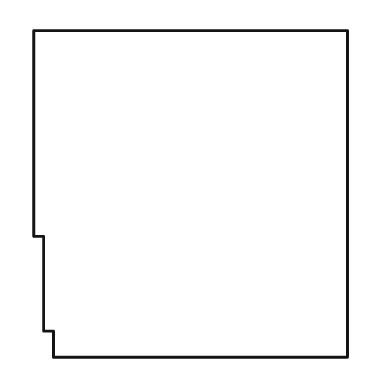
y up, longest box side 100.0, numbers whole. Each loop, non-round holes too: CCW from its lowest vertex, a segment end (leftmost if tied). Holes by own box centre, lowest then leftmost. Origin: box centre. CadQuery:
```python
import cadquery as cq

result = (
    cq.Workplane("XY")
    .moveTo(-42.0, -50.0)
    .lineTo(48.0, -50.0)
    .lineTo(48.0, 50.0)
    .lineTo(-48.0, 50.0)
    .lineTo(-48.0, -13.0)
    .lineTo(-45.0, -13.0)
    .lineTo(-45.0, -42.0)
    .lineTo(-42.0, -42.0)
    .close()
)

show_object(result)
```